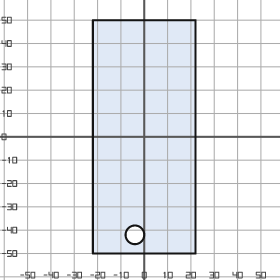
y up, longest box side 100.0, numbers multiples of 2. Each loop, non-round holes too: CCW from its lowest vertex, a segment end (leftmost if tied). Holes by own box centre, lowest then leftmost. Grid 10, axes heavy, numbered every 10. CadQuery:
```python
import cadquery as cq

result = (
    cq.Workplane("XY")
    .moveTo(-22.0, -50.0)
    .lineTo(22.0, -50.0)
    .lineTo(22.0, 50.0)
    .lineTo(-22.0, 50.0)
    .close()
    .moveTo(-4.0, -42.0)
    .circle(4.0)
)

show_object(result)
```